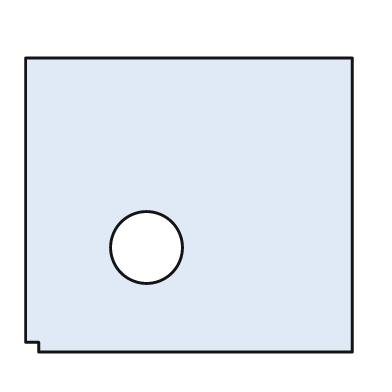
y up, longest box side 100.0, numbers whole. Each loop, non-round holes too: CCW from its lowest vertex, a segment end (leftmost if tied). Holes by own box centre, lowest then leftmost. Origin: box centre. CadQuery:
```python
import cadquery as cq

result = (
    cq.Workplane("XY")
    .moveTo(-46.0, -45.0)
    .lineTo(50.0, -45.0)
    .lineTo(50.0, 45.0)
    .lineTo(-50.0, 45.0)
    .lineTo(-50.0, -42.0)
    .lineTo(-46.0, -42.0)
    .close()
    .moveTo(-13.0, -13.0)
    .circle(11.0)
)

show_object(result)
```